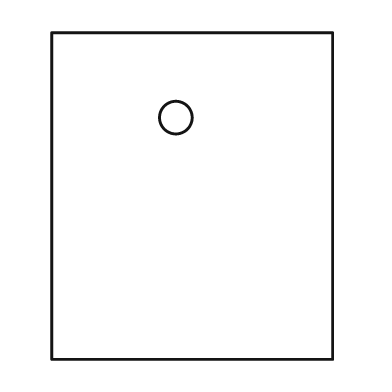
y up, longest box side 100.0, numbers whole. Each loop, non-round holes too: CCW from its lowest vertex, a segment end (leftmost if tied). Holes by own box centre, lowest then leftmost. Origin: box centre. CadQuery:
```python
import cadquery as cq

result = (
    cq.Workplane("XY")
    .moveTo(-43.0, -50.0)
    .lineTo(43.0, -50.0)
    .lineTo(43.0, 50.0)
    .lineTo(-43.0, 50.0)
    .close()
    .moveTo(-5.0, 24.0)
    .circle(5.0)
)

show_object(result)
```